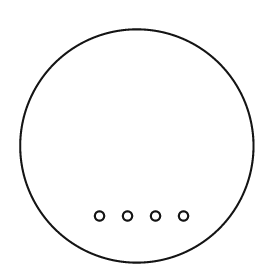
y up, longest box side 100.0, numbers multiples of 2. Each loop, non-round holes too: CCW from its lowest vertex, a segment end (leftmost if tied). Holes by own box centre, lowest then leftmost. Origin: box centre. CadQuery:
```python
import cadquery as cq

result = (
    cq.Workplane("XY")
    .moveTo(0.0, 0.0)
    .circle(50.0)
    .moveTo(-16.0, -30.0)
    .circle(2.0)
    .moveTo(-4.0, -30.0)
    .circle(2.0)
    .moveTo(8.0, -30.0)
    .circle(2.0)
    .moveTo(20.0, -30.0)
    .circle(2.0)
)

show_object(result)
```